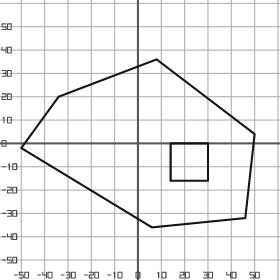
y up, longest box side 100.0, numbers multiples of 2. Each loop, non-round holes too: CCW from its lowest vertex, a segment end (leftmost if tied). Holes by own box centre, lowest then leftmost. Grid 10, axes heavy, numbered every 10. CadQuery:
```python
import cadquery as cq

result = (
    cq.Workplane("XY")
    .moveTo(6.0, -36.0)
    .lineTo(46.0, -32.0)
    .lineTo(50.0, 4.0)
    .lineTo(8.0, 36.0)
    .lineTo(-34.0, 20.0)
    .lineTo(-50.0, -2.0)
    .close()
    .moveTo(14.0, -16.0)
    .lineTo(30.0, -16.0)
    .lineTo(30.0, 0.0)
    .lineTo(14.0, 0.0)
    .close()
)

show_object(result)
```